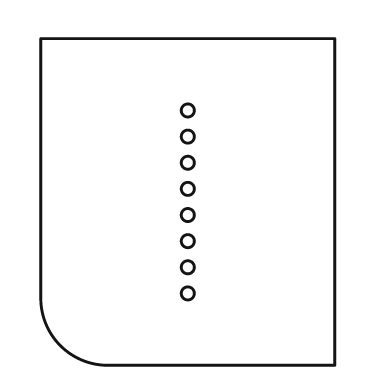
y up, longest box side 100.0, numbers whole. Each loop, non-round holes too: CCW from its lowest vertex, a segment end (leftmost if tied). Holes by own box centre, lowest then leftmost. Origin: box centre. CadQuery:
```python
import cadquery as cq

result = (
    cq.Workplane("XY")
    .moveTo(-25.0, -50.0)
    .lineTo(45.0, -50.0)
    .lineTo(45.0, 50.0)
    .lineTo(-45.0, 50.0)
    .lineTo(-45.0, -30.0)
    .threePointArc((-39.0, -44.0), (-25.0, -50.0))
    .close()
    .moveTo(0.0, -28.0)
    .circle(2.0)
    .moveTo(0.0, -20.0)
    .circle(2.0)
    .moveTo(0.0, -12.0)
    .circle(2.0)
    .moveTo(0.0, -4.0)
    .circle(2.0)
    .moveTo(0.0, 4.0)
    .circle(2.0)
    .moveTo(0.0, 12.0)
    .circle(2.0)
    .moveTo(0.0, 20.0)
    .circle(2.0)
    .moveTo(0.0, 28.0)
    .circle(2.0)
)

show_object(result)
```